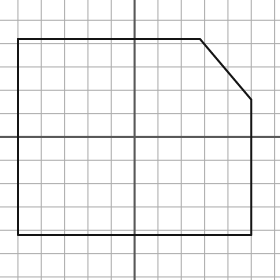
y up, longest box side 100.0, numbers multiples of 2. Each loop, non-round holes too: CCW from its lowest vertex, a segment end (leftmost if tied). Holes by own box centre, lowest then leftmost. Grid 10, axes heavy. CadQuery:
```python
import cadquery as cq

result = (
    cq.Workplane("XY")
    .moveTo(-50.0, -42.0)
    .lineTo(50.0, -42.0)
    .lineTo(50.0, 16.0)
    .lineTo(28.0, 42.0)
    .lineTo(-50.0, 42.0)
    .close()
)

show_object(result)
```